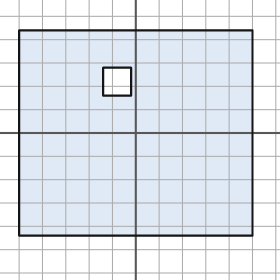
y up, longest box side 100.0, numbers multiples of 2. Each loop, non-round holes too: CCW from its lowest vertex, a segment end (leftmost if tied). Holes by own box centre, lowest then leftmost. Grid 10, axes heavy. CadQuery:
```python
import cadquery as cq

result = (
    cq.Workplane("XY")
    .moveTo(-50.0, -44.0)
    .lineTo(50.0, -44.0)
    .lineTo(50.0, 44.0)
    .lineTo(-50.0, 44.0)
    .close()
    .moveTo(-14.0, 16.0)
    .lineTo(-2.0, 16.0)
    .lineTo(-2.0, 28.0)
    .lineTo(-14.0, 28.0)
    .close()
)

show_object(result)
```